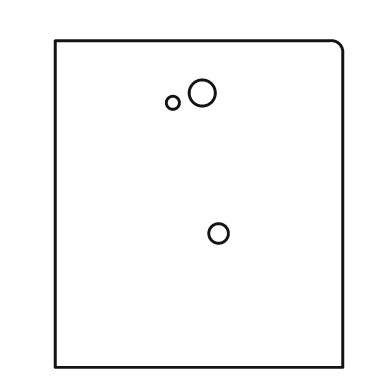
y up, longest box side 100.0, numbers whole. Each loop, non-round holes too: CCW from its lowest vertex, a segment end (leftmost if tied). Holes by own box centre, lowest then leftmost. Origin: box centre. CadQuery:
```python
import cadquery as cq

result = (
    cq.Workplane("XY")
    .moveTo(-44.0, -50.0)
    .lineTo(44.0, -50.0)
    .lineTo(44.0, 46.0)
    .threePointArc((43.0, 49.0), (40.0, 50.0))
    .lineTo(-44.0, 50.0)
    .close()
    .moveTo(6.0, -9.0)
    .circle(3.0)
    .moveTo(-8.0, 31.0)
    .circle(2.0)
    .moveTo(1.0, 34.0)
    .circle(4.0)
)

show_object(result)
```